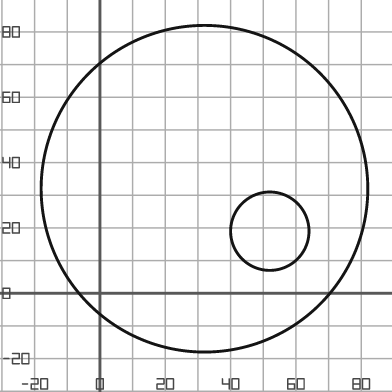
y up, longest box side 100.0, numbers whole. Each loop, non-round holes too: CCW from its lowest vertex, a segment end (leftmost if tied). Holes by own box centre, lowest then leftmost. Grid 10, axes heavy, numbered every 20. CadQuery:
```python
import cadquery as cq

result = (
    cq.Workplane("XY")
    .moveTo(32.0, 32.0)
    .circle(50.0)
    .moveTo(52.0, 19.0)
    .circle(12.0)
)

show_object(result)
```